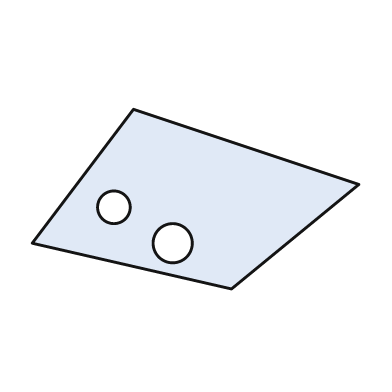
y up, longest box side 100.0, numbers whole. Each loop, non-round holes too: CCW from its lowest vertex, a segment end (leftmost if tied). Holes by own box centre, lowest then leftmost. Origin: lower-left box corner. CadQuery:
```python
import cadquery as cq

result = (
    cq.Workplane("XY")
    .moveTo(61.0, 0.0)
    .lineTo(100.0, 32.0)
    .lineTo(31.0, 55.0)
    .lineTo(0.0, 14.0)
    .close()
    .moveTo(43.0, 14.0)
    .circle(6.0)
    .moveTo(25.0, 25.0)
    .circle(5.0)
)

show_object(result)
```